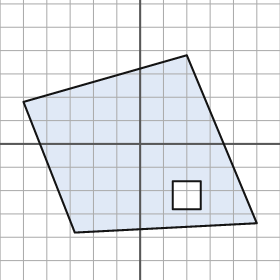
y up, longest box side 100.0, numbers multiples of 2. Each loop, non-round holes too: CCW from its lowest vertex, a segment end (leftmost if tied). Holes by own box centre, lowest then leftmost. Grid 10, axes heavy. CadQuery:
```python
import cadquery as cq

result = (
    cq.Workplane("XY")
    .moveTo(-28.0, -38.0)
    .lineTo(50.0, -34.0)
    .lineTo(20.0, 38.0)
    .lineTo(-50.0, 18.0)
    .close()
    .moveTo(14.0, -28.0)
    .lineTo(26.0, -28.0)
    .lineTo(26.0, -16.0)
    .lineTo(14.0, -16.0)
    .close()
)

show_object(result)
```